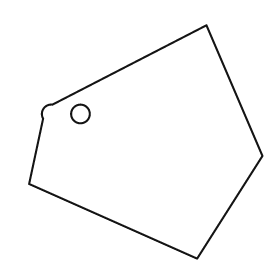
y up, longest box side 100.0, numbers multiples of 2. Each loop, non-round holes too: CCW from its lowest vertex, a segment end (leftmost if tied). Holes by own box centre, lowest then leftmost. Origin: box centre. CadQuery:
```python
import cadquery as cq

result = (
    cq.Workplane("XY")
    .moveTo(22.0, -50.0)
    .lineTo(50.0, -6.0)
    .lineTo(26.0, 50.0)
    .lineTo(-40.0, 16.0)
    .threePointArc((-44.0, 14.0), (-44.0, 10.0))
    .lineTo(-50.0, -18.0)
    .close()
    .moveTo(-28.0, 12.0)
    .circle(4.0)
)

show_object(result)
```